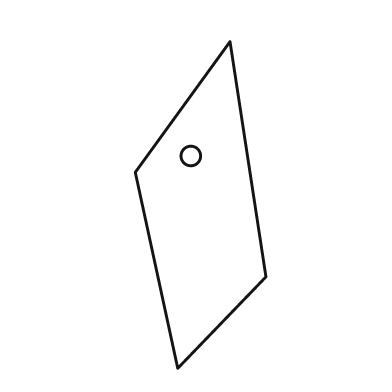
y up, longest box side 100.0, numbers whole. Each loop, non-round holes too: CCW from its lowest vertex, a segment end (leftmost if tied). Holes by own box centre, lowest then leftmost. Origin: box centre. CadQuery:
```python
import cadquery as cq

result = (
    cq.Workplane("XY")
    .moveTo(-7.0, -50.0)
    .lineTo(20.0, -22.0)
    .lineTo(9.0, 50.0)
    .lineTo(-20.0, 10.0)
    .close()
    .moveTo(-3.0, 15.0)
    .circle(3.0)
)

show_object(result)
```